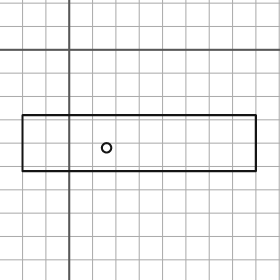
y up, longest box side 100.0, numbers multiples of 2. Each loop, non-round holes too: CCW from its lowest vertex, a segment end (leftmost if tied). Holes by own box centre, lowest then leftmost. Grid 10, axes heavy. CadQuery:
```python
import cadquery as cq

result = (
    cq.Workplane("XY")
    .moveTo(-20.0, -52.0)
    .lineTo(80.0, -52.0)
    .lineTo(80.0, -28.0)
    .lineTo(-20.0, -28.0)
    .close()
    .moveTo(16.0, -42.0)
    .circle(2.0)
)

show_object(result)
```